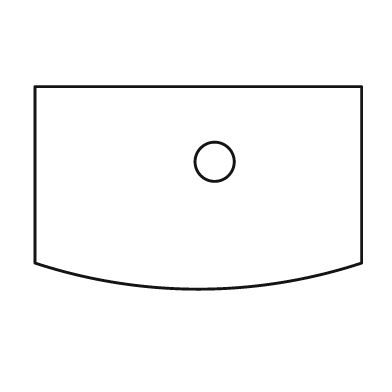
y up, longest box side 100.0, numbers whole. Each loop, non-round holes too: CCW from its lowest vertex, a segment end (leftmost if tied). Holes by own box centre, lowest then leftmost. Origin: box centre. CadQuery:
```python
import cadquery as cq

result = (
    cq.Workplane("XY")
    .moveTo(-50.0, -23.0)
    .threePointArc((0.0, -31.0), (50.0, -23.0))
    .lineTo(50.0, 31.0)
    .lineTo(-50.0, 31.0)
    .close()
    .moveTo(5.0, 8.0)
    .circle(6.0)
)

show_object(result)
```